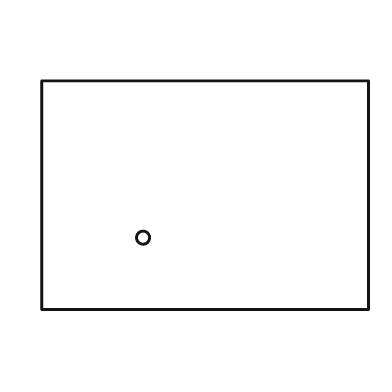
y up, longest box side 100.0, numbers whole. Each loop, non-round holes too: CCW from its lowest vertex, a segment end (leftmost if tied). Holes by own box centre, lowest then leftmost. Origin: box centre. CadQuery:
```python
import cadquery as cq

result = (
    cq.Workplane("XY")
    .moveTo(-50.0, -35.0)
    .lineTo(50.0, -35.0)
    .lineTo(50.0, 35.0)
    .lineTo(-50.0, 35.0)
    .close()
    .moveTo(-19.0, -13.0)
    .circle(2.0)
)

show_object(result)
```